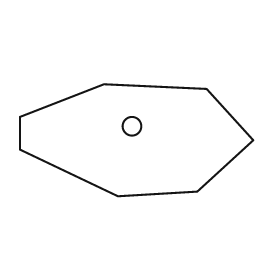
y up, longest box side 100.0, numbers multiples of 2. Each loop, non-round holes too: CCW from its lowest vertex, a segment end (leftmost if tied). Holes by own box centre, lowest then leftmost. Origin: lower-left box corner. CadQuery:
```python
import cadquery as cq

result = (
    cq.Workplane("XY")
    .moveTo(42.0, 0.0)
    .lineTo(76.0, 2.0)
    .lineTo(100.0, 24.0)
    .lineTo(80.0, 46.0)
    .lineTo(36.0, 48.0)
    .lineTo(0.0, 34.0)
    .lineTo(0.0, 20.0)
    .close()
    .moveTo(48.0, 30.0)
    .circle(4.0)
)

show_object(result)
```